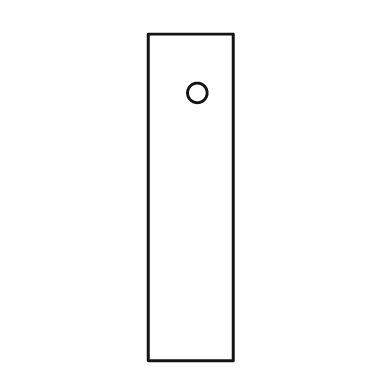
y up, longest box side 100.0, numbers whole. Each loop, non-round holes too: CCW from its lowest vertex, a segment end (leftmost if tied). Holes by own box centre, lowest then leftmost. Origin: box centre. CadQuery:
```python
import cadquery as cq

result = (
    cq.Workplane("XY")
    .moveTo(-13.0, -50.0)
    .lineTo(13.0, -50.0)
    .lineTo(13.0, 50.0)
    .lineTo(-13.0, 50.0)
    .close()
    .moveTo(2.0, 32.0)
    .circle(3.0)
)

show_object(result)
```